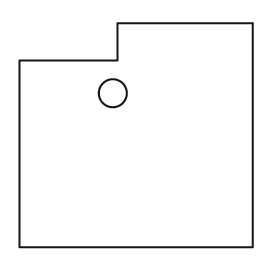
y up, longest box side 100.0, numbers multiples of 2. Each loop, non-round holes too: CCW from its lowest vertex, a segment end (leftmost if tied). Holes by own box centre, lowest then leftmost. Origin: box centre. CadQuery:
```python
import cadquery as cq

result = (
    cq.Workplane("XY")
    .moveTo(-50.0, -48.0)
    .lineTo(50.0, -48.0)
    .lineTo(50.0, 48.0)
    .lineTo(-8.0, 48.0)
    .lineTo(-8.0, 32.0)
    .lineTo(-50.0, 32.0)
    .close()
    .moveTo(-10.0, 18.0)
    .circle(6.0)
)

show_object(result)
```